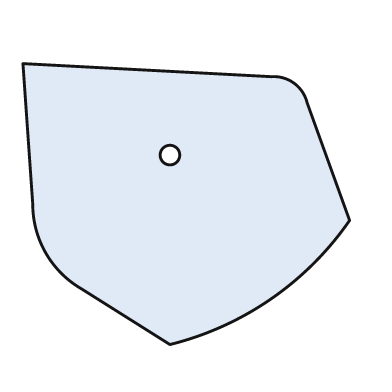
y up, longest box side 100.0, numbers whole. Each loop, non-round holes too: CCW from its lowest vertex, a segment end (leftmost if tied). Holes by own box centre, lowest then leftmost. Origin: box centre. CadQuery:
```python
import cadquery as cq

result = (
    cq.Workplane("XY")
    .moveTo(-5.0, -43.0)
    .threePointArc((26.0, -29.0), (50.0, -5.0))
    .lineTo(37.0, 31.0)
    .threePointArc((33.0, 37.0), (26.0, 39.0))
    .lineTo(-50.0, 43.0)
    .lineTo(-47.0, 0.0)
    .threePointArc((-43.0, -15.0), (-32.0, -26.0))
    .close()
    .moveTo(-5.0, 15.0)
    .circle(3.0)
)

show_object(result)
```